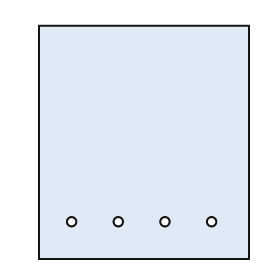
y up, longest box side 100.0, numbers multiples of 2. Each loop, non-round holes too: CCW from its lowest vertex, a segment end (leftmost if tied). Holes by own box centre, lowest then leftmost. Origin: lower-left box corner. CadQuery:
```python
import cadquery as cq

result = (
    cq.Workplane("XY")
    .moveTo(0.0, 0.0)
    .lineTo(90.0, 0.0)
    .lineTo(90.0, 100.0)
    .lineTo(0.0, 100.0)
    .close()
    .moveTo(14.0, 16.0)
    .circle(2.0)
    .moveTo(34.0, 16.0)
    .circle(2.0)
    .moveTo(54.0, 16.0)
    .circle(2.0)
    .moveTo(74.0, 16.0)
    .circle(2.0)
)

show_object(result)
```